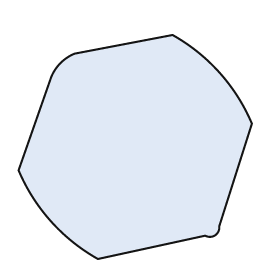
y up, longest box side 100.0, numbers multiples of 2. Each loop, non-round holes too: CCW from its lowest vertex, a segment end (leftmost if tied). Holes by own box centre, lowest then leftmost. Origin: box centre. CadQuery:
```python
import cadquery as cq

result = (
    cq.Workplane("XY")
    .moveTo(-16.0, -48.0)
    .lineTo(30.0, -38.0)
    .threePointArc((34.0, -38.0), (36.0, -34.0))
    .lineTo(50.0, 10.0)
    .threePointArc((36.0, 32.0), (16.0, 48.0))
    .lineTo(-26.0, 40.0)
    .threePointArc((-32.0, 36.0), (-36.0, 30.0))
    .lineTo(-50.0, -10.0)
    .threePointArc((-36.0, -32.0), (-16.0, -48.0))
    .close()
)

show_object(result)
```